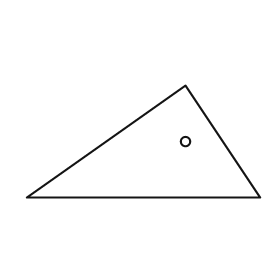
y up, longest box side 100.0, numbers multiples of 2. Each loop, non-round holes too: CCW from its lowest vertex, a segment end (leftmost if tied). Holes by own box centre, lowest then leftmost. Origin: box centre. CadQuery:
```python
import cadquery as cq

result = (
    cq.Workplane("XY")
    .moveTo(-50.0, -24.0)
    .lineTo(50.0, -24.0)
    .lineTo(18.0, 24.0)
    .close()
    .moveTo(18.0, 0.0)
    .circle(2.0)
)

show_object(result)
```